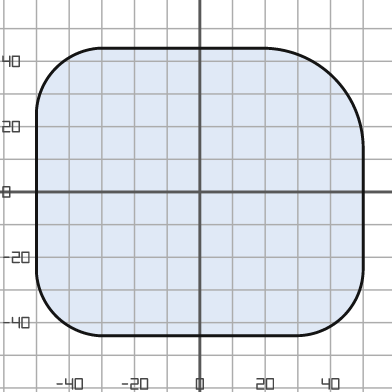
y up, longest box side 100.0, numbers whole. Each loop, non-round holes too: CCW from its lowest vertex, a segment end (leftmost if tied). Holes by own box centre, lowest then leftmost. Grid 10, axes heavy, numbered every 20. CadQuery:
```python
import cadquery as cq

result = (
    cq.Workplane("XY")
    .moveTo(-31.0, -44.0)
    .lineTo(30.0, -44.0)
    .threePointArc((44.0, -38.0), (50.0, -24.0))
    .lineTo(50.0, 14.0)
    .threePointArc((41.0, 35.0), (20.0, 44.0))
    .lineTo(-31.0, 44.0)
    .threePointArc((-44.0, 38.0), (-50.0, 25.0))
    .lineTo(-50.0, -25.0)
    .threePointArc((-44.0, -38.0), (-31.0, -44.0))
    .close()
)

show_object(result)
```